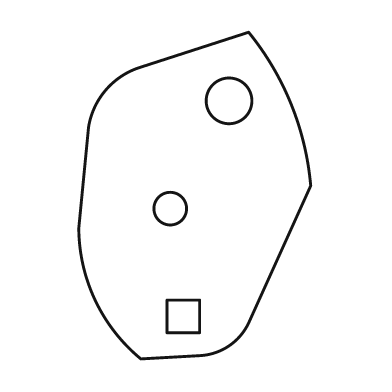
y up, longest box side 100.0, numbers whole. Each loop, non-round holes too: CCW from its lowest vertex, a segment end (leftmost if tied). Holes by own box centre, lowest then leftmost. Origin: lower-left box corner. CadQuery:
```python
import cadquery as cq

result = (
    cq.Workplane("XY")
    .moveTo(19.0, 0.0)
    .lineTo(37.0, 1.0)
    .threePointArc((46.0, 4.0), (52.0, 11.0))
    .lineTo(71.0, 53.0)
    .threePointArc((65.0, 78.0), (52.0, 100.0))
    .lineTo(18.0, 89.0)
    .threePointArc((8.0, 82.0), (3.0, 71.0))
    .lineTo(0.0, 40.0)
    .threePointArc((5.0, 18.0), (19.0, 0.0))
    .close()
    .moveTo(27.0, 8.0)
    .lineTo(37.0, 8.0)
    .lineTo(37.0, 18.0)
    .lineTo(27.0, 18.0)
    .close()
    .moveTo(28.0, 46.0)
    .circle(5.0)
    .moveTo(46.0, 79.0)
    .circle(7.0)
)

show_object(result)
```